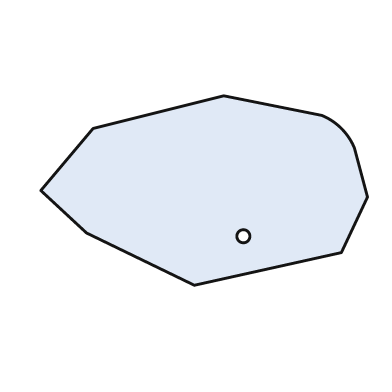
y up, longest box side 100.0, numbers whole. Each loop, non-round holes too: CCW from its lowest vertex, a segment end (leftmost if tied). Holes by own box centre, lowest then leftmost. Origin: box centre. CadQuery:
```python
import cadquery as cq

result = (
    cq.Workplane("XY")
    .moveTo(-3.0, -29.0)
    .lineTo(42.0, -19.0)
    .lineTo(50.0, -2.0)
    .lineTo(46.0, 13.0)
    .threePointArc((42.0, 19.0), (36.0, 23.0))
    .lineTo(6.0, 29.0)
    .lineTo(-34.0, 19.0)
    .lineTo(-50.0, 0.0)
    .lineTo(-36.0, -13.0)
    .close()
    .moveTo(12.0, -14.0)
    .circle(2.0)
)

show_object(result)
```